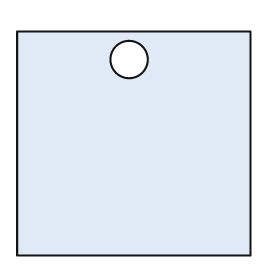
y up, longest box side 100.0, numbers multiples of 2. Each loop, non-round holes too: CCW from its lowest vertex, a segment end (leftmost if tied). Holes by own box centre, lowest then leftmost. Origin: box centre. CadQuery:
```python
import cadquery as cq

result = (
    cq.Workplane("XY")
    .moveTo(-50.0, -48.0)
    .lineTo(50.0, -48.0)
    .lineTo(50.0, 48.0)
    .lineTo(-50.0, 48.0)
    .close()
    .moveTo(-2.0, 36.0)
    .circle(8.0)
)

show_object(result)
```